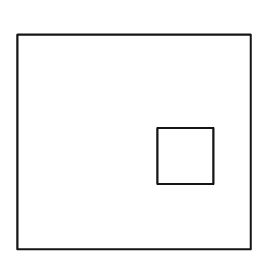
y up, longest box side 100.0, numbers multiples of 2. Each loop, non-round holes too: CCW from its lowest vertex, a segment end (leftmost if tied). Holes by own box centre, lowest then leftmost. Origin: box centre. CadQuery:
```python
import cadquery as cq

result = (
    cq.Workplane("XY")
    .moveTo(-50.0, -46.0)
    .lineTo(50.0, -46.0)
    .lineTo(50.0, 46.0)
    .lineTo(-50.0, 46.0)
    .close()
    .moveTo(10.0, -18.0)
    .lineTo(34.0, -18.0)
    .lineTo(34.0, 6.0)
    .lineTo(10.0, 6.0)
    .close()
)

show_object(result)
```